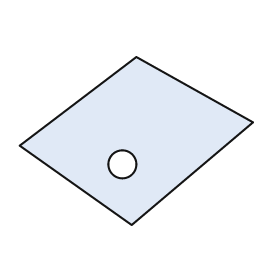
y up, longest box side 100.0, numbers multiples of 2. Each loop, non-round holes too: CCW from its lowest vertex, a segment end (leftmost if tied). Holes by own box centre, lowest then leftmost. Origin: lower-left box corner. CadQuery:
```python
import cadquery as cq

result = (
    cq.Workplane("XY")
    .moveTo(48.0, 0.0)
    .lineTo(100.0, 44.0)
    .lineTo(50.0, 72.0)
    .lineTo(0.0, 34.0)
    .close()
    .moveTo(44.0, 26.0)
    .circle(6.0)
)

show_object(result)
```